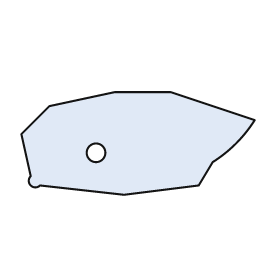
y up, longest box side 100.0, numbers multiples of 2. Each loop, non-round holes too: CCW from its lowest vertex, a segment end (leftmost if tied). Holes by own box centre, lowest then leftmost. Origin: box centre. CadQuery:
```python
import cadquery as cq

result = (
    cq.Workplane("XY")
    .moveTo(-6.0, -22.0)
    .lineTo(26.0, -18.0)
    .lineTo(32.0, -8.0)
    .threePointArc((42.0, 0.0), (50.0, 10.0))
    .lineTo(14.0, 22.0)
    .lineTo(-10.0, 22.0)
    .lineTo(-38.0, 16.0)
    .lineTo(-50.0, 4.0)
    .lineTo(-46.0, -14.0)
    .threePointArc((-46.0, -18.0), (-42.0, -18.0))
    .close()
    .moveTo(-18.0, -4.0)
    .circle(4.0)
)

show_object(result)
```